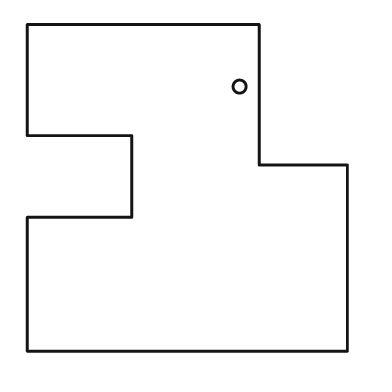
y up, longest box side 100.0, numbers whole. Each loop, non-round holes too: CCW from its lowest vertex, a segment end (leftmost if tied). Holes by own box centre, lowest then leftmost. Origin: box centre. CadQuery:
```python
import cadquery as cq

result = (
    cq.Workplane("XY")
    .moveTo(-49.0, -50.0)
    .lineTo(49.0, -50.0)
    .lineTo(49.0, 7.0)
    .lineTo(22.0, 7.0)
    .lineTo(22.0, 50.0)
    .lineTo(-49.0, 50.0)
    .lineTo(-49.0, 16.0)
    .lineTo(-17.0, 16.0)
    .lineTo(-17.0, -9.0)
    .lineTo(-49.0, -9.0)
    .close()
    .moveTo(16.0, 31.0)
    .circle(2.0)
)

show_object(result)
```